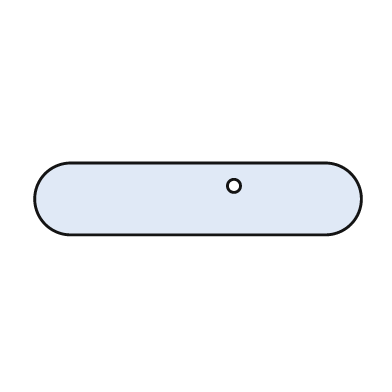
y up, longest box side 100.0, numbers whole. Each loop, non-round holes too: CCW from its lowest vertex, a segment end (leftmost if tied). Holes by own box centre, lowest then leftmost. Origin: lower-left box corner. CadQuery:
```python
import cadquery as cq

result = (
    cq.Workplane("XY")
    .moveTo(11.0, 0.0)
    .lineTo(89.0, 0.0)
    .threePointArc((100.0, 11.0), (89.0, 22.0))
    .lineTo(11.0, 22.0)
    .threePointArc((0.0, 11.0), (11.0, 0.0))
    .close()
    .moveTo(61.0, 15.0)
    .circle(2.0)
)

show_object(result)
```